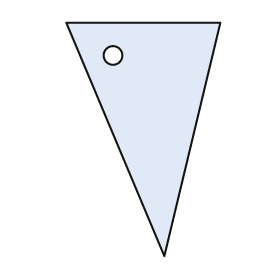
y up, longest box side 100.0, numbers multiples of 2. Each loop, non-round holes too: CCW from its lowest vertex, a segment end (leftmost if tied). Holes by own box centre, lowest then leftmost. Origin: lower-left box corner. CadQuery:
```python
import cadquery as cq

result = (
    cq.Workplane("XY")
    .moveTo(42.0, 0.0)
    .lineTo(66.0, 100.0)
    .lineTo(0.0, 100.0)
    .close()
    .moveTo(20.0, 86.0)
    .circle(4.0)
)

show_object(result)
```